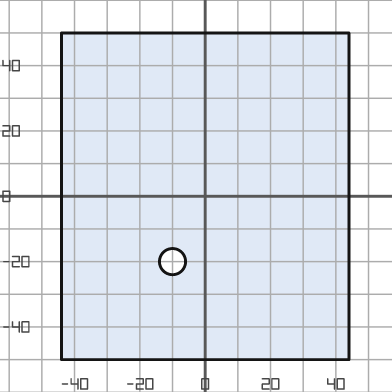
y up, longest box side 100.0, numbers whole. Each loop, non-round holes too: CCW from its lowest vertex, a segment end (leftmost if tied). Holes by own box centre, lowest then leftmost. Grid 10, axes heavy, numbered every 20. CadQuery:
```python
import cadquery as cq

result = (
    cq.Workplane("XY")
    .moveTo(-44.0, -50.0)
    .lineTo(44.0, -50.0)
    .lineTo(44.0, 50.0)
    .lineTo(-44.0, 50.0)
    .close()
    .moveTo(-10.0, -20.0)
    .circle(4.0)
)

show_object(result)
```